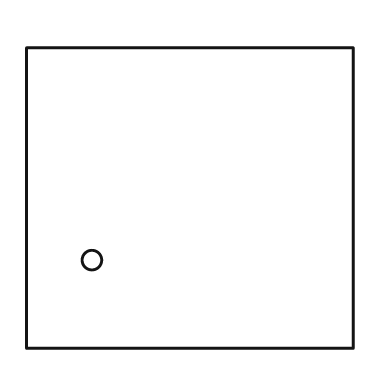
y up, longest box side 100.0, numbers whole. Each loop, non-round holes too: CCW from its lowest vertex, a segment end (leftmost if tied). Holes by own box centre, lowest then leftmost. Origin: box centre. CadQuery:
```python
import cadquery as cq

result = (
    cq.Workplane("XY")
    .moveTo(-50.0, -46.0)
    .lineTo(50.0, -46.0)
    .lineTo(50.0, 46.0)
    .lineTo(-50.0, 46.0)
    .close()
    .moveTo(-30.0, -19.0)
    .circle(3.0)
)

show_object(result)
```